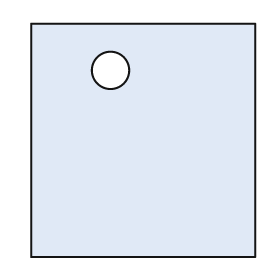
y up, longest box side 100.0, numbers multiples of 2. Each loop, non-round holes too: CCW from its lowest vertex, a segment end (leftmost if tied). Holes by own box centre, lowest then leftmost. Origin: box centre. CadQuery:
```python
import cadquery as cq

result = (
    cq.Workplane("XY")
    .moveTo(-48.0, -50.0)
    .lineTo(48.0, -50.0)
    .lineTo(48.0, 50.0)
    .lineTo(-48.0, 50.0)
    .close()
    .moveTo(-14.0, 30.0)
    .circle(8.0)
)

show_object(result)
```